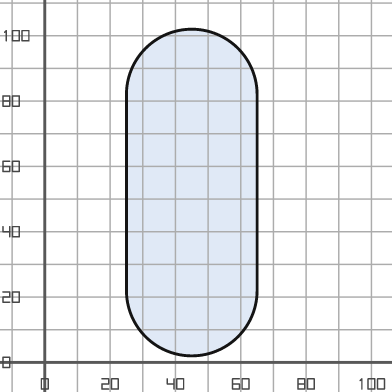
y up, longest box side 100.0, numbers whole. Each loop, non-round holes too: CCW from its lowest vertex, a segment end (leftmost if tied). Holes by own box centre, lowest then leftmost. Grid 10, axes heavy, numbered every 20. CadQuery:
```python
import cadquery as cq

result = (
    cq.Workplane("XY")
    .moveTo(25.0, 22.0)
    .threePointArc((45.0, 2.0), (65.0, 22.0))
    .lineTo(65.0, 82.0)
    .threePointArc((45.0, 102.0), (25.0, 82.0))
    .close()
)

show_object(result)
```